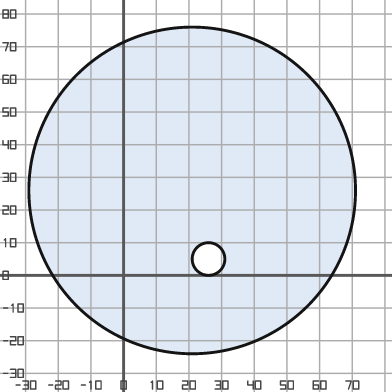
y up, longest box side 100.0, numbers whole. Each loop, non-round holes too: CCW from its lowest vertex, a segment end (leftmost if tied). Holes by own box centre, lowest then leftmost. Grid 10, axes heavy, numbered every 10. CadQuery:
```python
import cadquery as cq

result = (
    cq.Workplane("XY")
    .moveTo(21.0, 26.0)
    .circle(50.0)
    .moveTo(26.0, 5.0)
    .circle(5.0)
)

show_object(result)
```